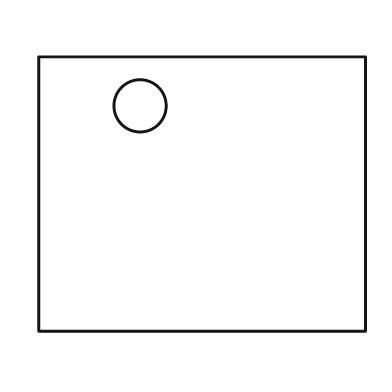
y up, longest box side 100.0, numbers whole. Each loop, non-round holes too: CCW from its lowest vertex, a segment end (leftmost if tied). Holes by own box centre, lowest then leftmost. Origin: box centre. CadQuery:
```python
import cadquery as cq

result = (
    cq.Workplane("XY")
    .moveTo(-50.0, -42.0)
    .lineTo(50.0, -42.0)
    .lineTo(50.0, 42.0)
    .lineTo(-50.0, 42.0)
    .close()
    .moveTo(-19.0, 27.0)
    .circle(8.0)
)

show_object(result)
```